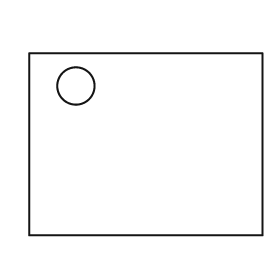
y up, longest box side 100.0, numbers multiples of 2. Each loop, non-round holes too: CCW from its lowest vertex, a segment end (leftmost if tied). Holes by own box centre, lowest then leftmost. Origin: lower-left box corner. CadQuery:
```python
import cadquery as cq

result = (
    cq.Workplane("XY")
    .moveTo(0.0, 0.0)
    .lineTo(100.0, 0.0)
    .lineTo(100.0, 78.0)
    .lineTo(0.0, 78.0)
    .close()
    .moveTo(20.0, 64.0)
    .circle(8.0)
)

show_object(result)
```